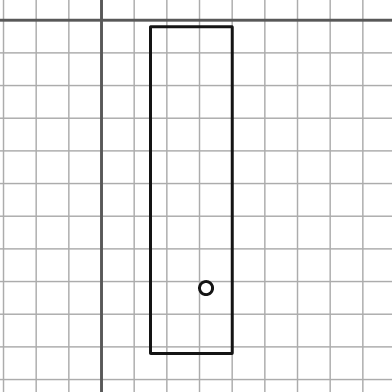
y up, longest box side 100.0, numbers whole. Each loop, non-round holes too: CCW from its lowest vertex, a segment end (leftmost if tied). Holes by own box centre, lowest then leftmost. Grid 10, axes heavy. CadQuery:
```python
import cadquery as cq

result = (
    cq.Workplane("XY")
    .moveTo(15.0, -102.0)
    .lineTo(40.0, -102.0)
    .lineTo(40.0, -2.0)
    .lineTo(15.0, -2.0)
    .close()
    .moveTo(32.0, -82.0)
    .circle(2.0)
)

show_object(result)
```